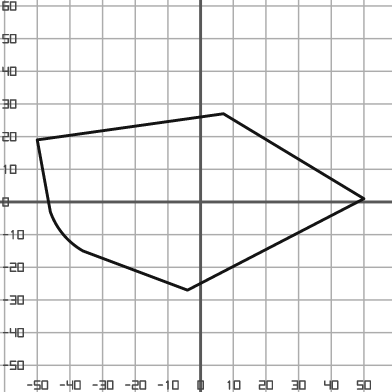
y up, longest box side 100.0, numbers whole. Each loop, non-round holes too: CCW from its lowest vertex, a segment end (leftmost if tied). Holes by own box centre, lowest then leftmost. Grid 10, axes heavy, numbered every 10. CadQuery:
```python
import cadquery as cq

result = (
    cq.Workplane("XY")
    .moveTo(-4.0, -27.0)
    .lineTo(50.0, 1.0)
    .lineTo(7.0, 27.0)
    .lineTo(-50.0, 19.0)
    .lineTo(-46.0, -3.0)
    .threePointArc((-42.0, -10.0), (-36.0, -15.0))
    .close()
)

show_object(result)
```